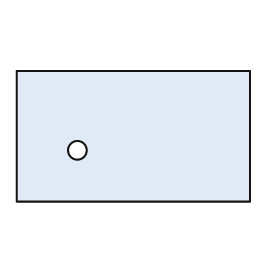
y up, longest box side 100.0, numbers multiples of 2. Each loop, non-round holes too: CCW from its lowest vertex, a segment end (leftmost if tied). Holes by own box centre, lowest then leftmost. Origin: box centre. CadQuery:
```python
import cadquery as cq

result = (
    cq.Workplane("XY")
    .moveTo(-50.0, -28.0)
    .lineTo(50.0, -28.0)
    .lineTo(50.0, 28.0)
    .lineTo(-50.0, 28.0)
    .close()
    .moveTo(-24.0, -6.0)
    .circle(4.0)
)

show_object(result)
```